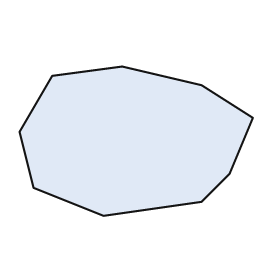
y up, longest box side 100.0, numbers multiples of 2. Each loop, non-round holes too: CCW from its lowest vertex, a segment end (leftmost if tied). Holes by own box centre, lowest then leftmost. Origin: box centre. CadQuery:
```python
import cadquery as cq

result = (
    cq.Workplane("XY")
    .moveTo(-14.0, -32.0)
    .lineTo(28.0, -26.0)
    .lineTo(40.0, -14.0)
    .lineTo(50.0, 10.0)
    .lineTo(28.0, 24.0)
    .lineTo(-6.0, 32.0)
    .lineTo(-36.0, 28.0)
    .lineTo(-50.0, 4.0)
    .lineTo(-44.0, -20.0)
    .close()
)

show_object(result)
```